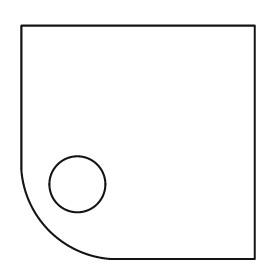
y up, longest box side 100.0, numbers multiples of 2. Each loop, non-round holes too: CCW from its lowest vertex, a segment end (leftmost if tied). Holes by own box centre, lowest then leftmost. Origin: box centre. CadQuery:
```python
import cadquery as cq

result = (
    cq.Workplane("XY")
    .moveTo(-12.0, -50.0)
    .lineTo(50.0, -50.0)
    .lineTo(50.0, 50.0)
    .lineTo(-50.0, 50.0)
    .lineTo(-50.0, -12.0)
    .threePointArc((-38.0, -38.0), (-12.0, -50.0))
    .close()
    .moveTo(-26.0, -18.0)
    .circle(12.0)
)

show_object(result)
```